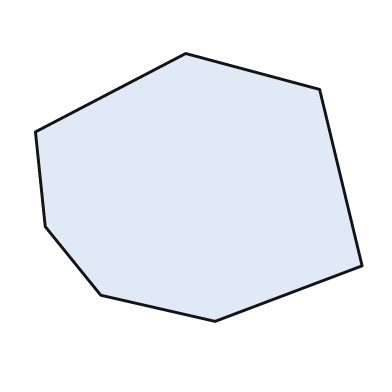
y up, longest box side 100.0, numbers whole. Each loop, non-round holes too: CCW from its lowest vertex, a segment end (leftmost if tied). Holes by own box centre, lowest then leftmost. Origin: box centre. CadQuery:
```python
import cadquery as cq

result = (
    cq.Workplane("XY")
    .moveTo(5.0, -41.0)
    .lineTo(50.0, -24.0)
    .lineTo(37.0, 30.0)
    .lineTo(-4.0, 41.0)
    .lineTo(-50.0, 17.0)
    .lineTo(-47.0, -12.0)
    .lineTo(-30.0, -33.0)
    .close()
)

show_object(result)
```